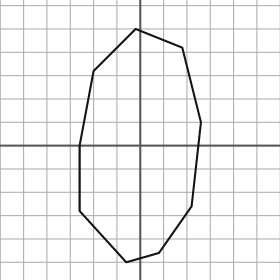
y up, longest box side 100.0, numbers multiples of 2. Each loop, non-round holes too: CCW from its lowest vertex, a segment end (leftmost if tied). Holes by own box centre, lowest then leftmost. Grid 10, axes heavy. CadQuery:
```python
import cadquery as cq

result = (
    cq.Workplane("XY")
    .moveTo(-6.0, -50.0)
    .lineTo(8.0, -46.0)
    .lineTo(22.0, -26.0)
    .lineTo(26.0, 10.0)
    .lineTo(18.0, 42.0)
    .lineTo(-2.0, 50.0)
    .lineTo(-20.0, 32.0)
    .lineTo(-26.0, 0.0)
    .lineTo(-26.0, -28.0)
    .close()
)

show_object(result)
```